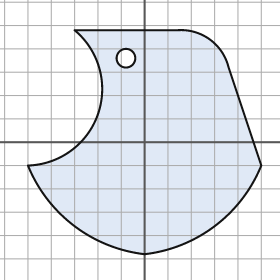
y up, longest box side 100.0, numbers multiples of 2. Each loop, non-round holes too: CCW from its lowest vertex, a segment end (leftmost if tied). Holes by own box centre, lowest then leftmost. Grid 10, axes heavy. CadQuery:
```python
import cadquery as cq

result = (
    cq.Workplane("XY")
    .moveTo(0.0, -48.0)
    .threePointArc((30.0, -36.0), (50.0, -10.0))
    .lineTo(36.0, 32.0)
    .threePointArc((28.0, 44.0), (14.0, 48.0))
    .lineTo(-30.0, 48.0)
    .threePointArc((-20.0, 12.0), (-50.0, -10.0))
    .threePointArc((-30.0, -36.0), (0.0, -48.0))
    .close()
    .moveTo(-8.0, 36.0)
    .circle(4.0)
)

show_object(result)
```